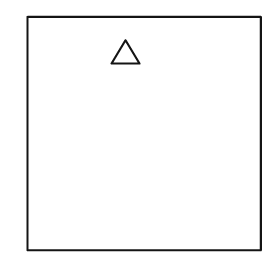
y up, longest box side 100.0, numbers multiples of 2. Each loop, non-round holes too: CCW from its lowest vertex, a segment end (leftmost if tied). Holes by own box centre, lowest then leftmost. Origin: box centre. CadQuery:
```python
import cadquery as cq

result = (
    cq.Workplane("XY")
    .moveTo(-50.0, -50.0)
    .lineTo(50.0, -50.0)
    .lineTo(50.0, 50.0)
    .lineTo(-50.0, 50.0)
    .close()
    .moveTo(-14.0, 30.0)
    .lineTo(-2.0, 30.0)
    .lineTo(-8.0, 40.0)
    .close()
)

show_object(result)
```